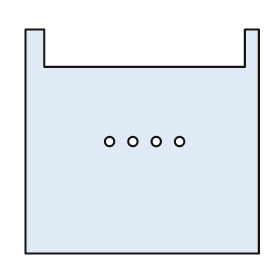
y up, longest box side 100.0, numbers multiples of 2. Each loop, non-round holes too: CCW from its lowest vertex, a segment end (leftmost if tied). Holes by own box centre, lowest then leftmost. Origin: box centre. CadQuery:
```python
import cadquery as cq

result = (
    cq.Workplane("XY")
    .moveTo(-50.0, -48.0)
    .lineTo(50.0, -48.0)
    .lineTo(50.0, 48.0)
    .lineTo(44.0, 48.0)
    .lineTo(44.0, 32.0)
    .lineTo(-42.0, 32.0)
    .lineTo(-42.0, 48.0)
    .lineTo(-50.0, 48.0)
    .close()
    .moveTo(-14.0, 0.0)
    .circle(2.0)
    .moveTo(-4.0, 0.0)
    .circle(2.0)
    .moveTo(6.0, 0.0)
    .circle(2.0)
    .moveTo(16.0, 0.0)
    .circle(2.0)
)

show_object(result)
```